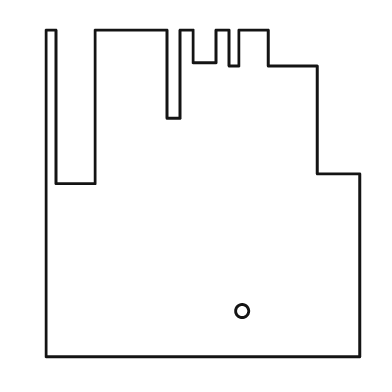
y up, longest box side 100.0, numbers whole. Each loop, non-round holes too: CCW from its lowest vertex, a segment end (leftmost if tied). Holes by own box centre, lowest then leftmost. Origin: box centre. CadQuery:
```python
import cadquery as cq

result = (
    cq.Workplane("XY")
    .moveTo(-48.0, -50.0)
    .lineTo(48.0, -50.0)
    .lineTo(48.0, 6.0)
    .lineTo(35.0, 6.0)
    .lineTo(35.0, 39.0)
    .lineTo(20.0, 39.0)
    .lineTo(20.0, 50.0)
    .lineTo(11.0, 50.0)
    .lineTo(11.0, 39.0)
    .lineTo(8.0, 39.0)
    .lineTo(8.0, 50.0)
    .lineTo(4.0, 50.0)
    .lineTo(4.0, 40.0)
    .lineTo(-3.0, 40.0)
    .lineTo(-3.0, 50.0)
    .lineTo(-7.0, 50.0)
    .lineTo(-7.0, 23.0)
    .lineTo(-11.0, 23.0)
    .lineTo(-11.0, 50.0)
    .lineTo(-33.0, 50.0)
    .lineTo(-33.0, 3.0)
    .lineTo(-45.0, 3.0)
    .lineTo(-45.0, 50.0)
    .lineTo(-48.0, 50.0)
    .close()
    .moveTo(12.0, -36.0)
    .circle(2.0)
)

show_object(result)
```